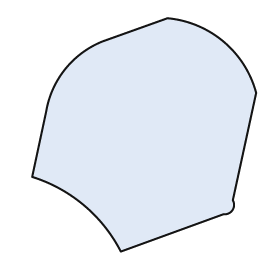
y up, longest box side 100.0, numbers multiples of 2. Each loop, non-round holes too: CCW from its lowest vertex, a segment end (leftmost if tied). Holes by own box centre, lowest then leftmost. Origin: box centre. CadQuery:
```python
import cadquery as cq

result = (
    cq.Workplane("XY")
    .moveTo(-10.0, -50.0)
    .lineTo(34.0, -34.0)
    .threePointArc((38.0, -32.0), (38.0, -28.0))
    .lineTo(48.0, 18.0)
    .threePointArc((34.0, 40.0), (10.0, 50.0))
    .lineTo(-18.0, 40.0)
    .threePointArc((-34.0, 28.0), (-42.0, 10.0))
    .lineTo(-48.0, -18.0)
    .threePointArc((-26.0, -30.0), (-10.0, -50.0))
    .close()
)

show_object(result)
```